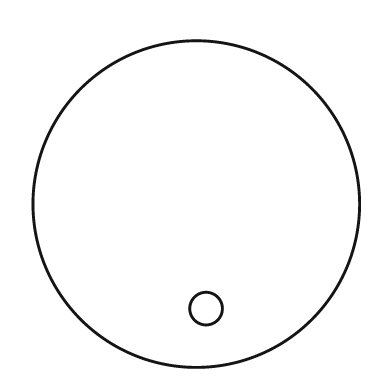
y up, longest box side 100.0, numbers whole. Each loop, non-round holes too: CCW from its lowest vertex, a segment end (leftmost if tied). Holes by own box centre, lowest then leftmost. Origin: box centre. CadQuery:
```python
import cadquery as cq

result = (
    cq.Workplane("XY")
    .moveTo(0.0, 0.0)
    .circle(50.0)
    .moveTo(3.0, -32.0)
    .circle(5.0)
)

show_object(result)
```